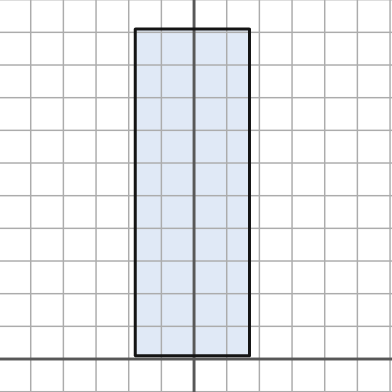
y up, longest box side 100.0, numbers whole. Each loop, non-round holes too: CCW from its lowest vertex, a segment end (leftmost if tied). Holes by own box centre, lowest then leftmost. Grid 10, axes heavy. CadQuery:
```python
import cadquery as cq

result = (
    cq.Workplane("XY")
    .moveTo(-18.0, 1.0)
    .lineTo(17.0, 1.0)
    .lineTo(17.0, 101.0)
    .lineTo(-18.0, 101.0)
    .close()
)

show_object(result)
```